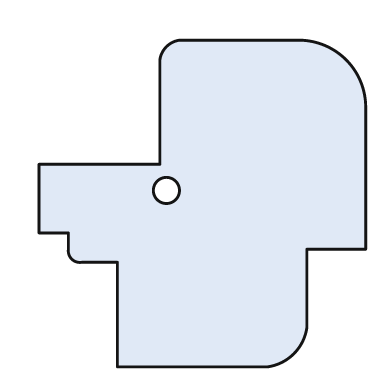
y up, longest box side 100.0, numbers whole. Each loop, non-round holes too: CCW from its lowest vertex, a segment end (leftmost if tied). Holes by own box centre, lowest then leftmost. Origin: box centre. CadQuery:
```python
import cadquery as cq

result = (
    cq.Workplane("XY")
    .moveTo(-26.0, -50.0)
    .lineTo(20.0, -50.0)
    .threePointArc((28.0, -46.0), (32.0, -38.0))
    .lineTo(32.0, -14.0)
    .lineTo(50.0, -14.0)
    .lineTo(50.0, 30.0)
    .threePointArc((44.0, 44.0), (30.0, 50.0))
    .lineTo(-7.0, 50.0)
    .threePointArc((-11.0, 48.0), (-13.0, 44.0))
    .lineTo(-13.0, 12.0)
    .lineTo(-50.0, 12.0)
    .lineTo(-50.0, -9.0)
    .lineTo(-41.0, -9.0)
    .lineTo(-41.0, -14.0)
    .threePointArc((-40.0, -17.0), (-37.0, -18.0))
    .lineTo(-26.0, -18.0)
    .close()
    .moveTo(-11.0, 4.0)
    .circle(4.0)
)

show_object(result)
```